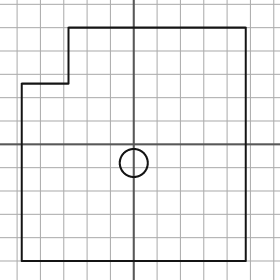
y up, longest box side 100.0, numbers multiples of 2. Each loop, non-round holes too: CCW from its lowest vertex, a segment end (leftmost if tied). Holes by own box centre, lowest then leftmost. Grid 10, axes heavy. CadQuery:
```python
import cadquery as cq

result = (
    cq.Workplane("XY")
    .moveTo(-48.0, -50.0)
    .lineTo(48.0, -50.0)
    .lineTo(48.0, 50.0)
    .lineTo(-28.0, 50.0)
    .lineTo(-28.0, 26.0)
    .lineTo(-48.0, 26.0)
    .close()
    .moveTo(0.0, -8.0)
    .circle(6.0)
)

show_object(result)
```